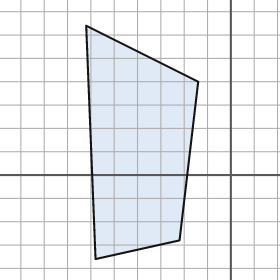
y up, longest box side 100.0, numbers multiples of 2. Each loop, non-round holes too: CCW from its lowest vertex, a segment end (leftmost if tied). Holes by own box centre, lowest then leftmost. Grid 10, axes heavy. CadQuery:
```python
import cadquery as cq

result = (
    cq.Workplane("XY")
    .moveTo(-58.0, -36.0)
    .lineTo(-22.0, -28.0)
    .lineTo(-14.0, 40.0)
    .lineTo(-62.0, 64.0)
    .close()
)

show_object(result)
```